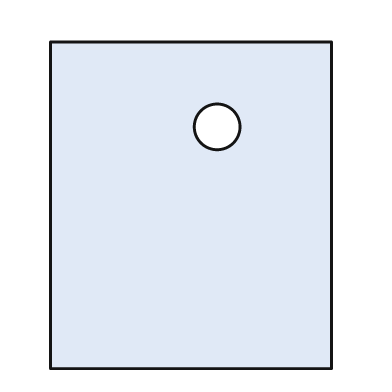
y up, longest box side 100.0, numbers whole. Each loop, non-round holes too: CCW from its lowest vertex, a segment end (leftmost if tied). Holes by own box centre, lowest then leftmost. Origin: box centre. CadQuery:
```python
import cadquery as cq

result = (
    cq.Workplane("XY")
    .moveTo(-43.0, -50.0)
    .lineTo(43.0, -50.0)
    .lineTo(43.0, 50.0)
    .lineTo(-43.0, 50.0)
    .close()
    .moveTo(8.0, 24.0)
    .circle(7.0)
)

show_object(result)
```